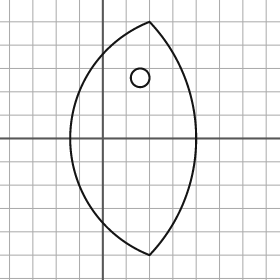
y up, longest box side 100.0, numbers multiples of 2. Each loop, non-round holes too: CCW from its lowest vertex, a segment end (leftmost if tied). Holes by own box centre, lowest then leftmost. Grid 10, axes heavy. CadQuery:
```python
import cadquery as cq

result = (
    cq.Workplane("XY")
    .moveTo(20.0, -50.0)
    .threePointArc((40.0, 0.0), (20.0, 50.0))
    .threePointArc((-14.0, 0.0), (20.0, -50.0))
    .close()
    .moveTo(16.0, 26.0)
    .circle(4.0)
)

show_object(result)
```